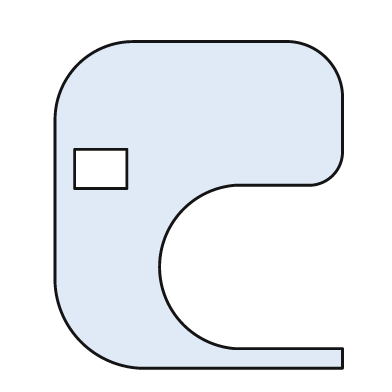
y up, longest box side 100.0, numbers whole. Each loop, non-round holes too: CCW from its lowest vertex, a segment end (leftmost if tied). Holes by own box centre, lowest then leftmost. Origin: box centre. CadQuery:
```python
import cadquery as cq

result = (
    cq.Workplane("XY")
    .moveTo(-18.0, -50.0)
    .lineTo(44.0, -50.0)
    .lineTo(44.0, -44.0)
    .lineTo(11.0, -44.0)
    .threePointArc((-12.0, -19.0), (11.0, 6.0))
    .lineTo(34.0, 6.0)
    .threePointArc((41.0, 9.0), (44.0, 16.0))
    .lineTo(44.0, 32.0)
    .threePointArc((39.0, 45.0), (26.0, 50.0))
    .lineTo(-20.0, 50.0)
    .threePointArc((-37.0, 43.0), (-44.0, 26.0))
    .lineTo(-44.0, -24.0)
    .threePointArc((-36.0, -42.0), (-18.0, -50.0))
    .close()
    .moveTo(-38.0, 5.0)
    .lineTo(-22.0, 5.0)
    .lineTo(-22.0, 17.0)
    .lineTo(-38.0, 17.0)
    .close()
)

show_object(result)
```